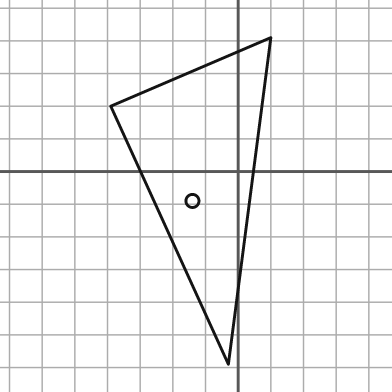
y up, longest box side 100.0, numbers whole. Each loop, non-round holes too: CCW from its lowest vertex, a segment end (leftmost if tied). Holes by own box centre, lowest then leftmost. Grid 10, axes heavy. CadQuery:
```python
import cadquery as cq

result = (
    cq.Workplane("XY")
    .moveTo(-3.0, -59.0)
    .lineTo(10.0, 41.0)
    .lineTo(-39.0, 20.0)
    .close()
    .moveTo(-14.0, -9.0)
    .circle(2.0)
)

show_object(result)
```